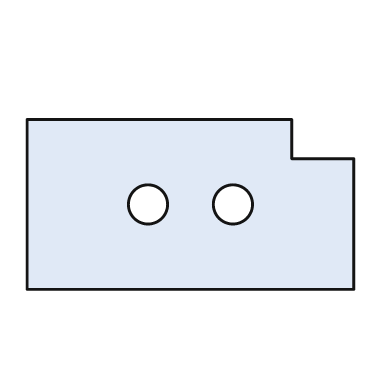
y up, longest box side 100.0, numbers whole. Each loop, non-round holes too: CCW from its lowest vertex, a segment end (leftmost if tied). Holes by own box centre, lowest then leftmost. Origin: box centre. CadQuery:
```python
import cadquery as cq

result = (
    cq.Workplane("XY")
    .moveTo(-50.0, -26.0)
    .lineTo(50.0, -26.0)
    .lineTo(50.0, 14.0)
    .lineTo(31.0, 14.0)
    .lineTo(31.0, 26.0)
    .lineTo(-50.0, 26.0)
    .close()
    .moveTo(-13.0, 0.0)
    .circle(6.0)
    .moveTo(13.0, 0.0)
    .circle(6.0)
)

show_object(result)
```